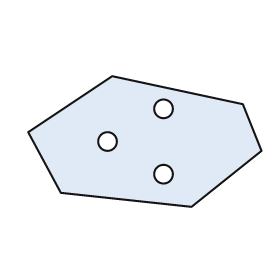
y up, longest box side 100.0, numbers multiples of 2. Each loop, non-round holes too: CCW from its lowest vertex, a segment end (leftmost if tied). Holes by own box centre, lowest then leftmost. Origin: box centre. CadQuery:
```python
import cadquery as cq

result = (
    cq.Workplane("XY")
    .moveTo(20.0, -28.0)
    .lineTo(50.0, -4.0)
    .lineTo(42.0, 16.0)
    .lineTo(-14.0, 28.0)
    .lineTo(-50.0, 4.0)
    .lineTo(-36.0, -22.0)
    .close()
    .moveTo(8.0, -14.0)
    .circle(4.0)
    .moveTo(-16.0, 0.0)
    .circle(4.0)
    .moveTo(8.0, 14.0)
    .circle(4.0)
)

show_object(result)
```